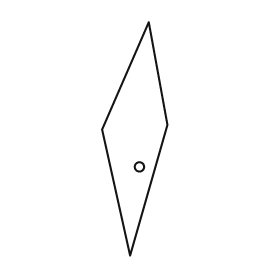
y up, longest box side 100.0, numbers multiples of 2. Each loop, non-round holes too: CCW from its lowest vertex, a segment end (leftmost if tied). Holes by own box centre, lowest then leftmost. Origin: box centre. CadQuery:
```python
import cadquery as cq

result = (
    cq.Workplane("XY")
    .moveTo(-2.0, -50.0)
    .lineTo(14.0, 6.0)
    .lineTo(6.0, 50.0)
    .lineTo(-14.0, 4.0)
    .close()
    .moveTo(2.0, -12.0)
    .circle(2.0)
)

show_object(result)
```